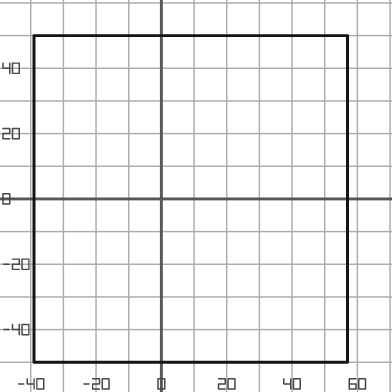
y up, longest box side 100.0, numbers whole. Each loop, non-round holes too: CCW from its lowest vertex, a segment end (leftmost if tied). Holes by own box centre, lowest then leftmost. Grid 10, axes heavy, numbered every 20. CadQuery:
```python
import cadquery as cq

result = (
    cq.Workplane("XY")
    .moveTo(-39.0, -50.0)
    .lineTo(57.0, -50.0)
    .lineTo(57.0, 50.0)
    .lineTo(-39.0, 50.0)
    .close()
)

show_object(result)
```